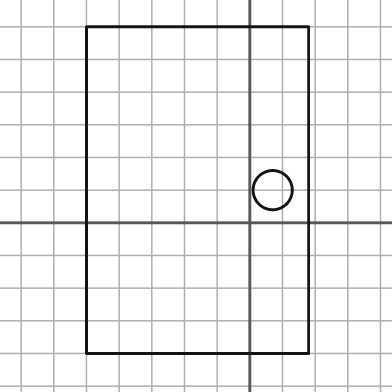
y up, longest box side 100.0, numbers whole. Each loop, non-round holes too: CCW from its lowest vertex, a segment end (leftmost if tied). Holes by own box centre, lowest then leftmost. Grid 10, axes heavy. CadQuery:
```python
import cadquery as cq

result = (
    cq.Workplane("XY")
    .moveTo(-50.0, -40.0)
    .lineTo(18.0, -40.0)
    .lineTo(18.0, 60.0)
    .lineTo(-50.0, 60.0)
    .close()
    .moveTo(7.0, 10.0)
    .circle(6.0)
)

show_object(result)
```